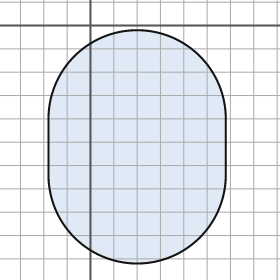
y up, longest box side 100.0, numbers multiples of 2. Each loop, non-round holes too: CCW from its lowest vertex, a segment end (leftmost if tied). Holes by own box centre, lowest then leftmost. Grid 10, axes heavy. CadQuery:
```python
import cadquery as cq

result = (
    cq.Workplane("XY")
    .moveTo(-18.0, -64.0)
    .threePointArc((20.0, -102.0), (58.0, -64.0))
    .lineTo(58.0, -40.0)
    .threePointArc((20.0, -2.0), (-18.0, -40.0))
    .close()
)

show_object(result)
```